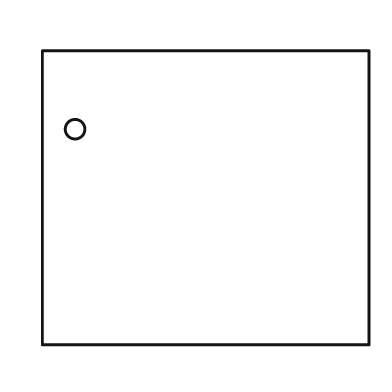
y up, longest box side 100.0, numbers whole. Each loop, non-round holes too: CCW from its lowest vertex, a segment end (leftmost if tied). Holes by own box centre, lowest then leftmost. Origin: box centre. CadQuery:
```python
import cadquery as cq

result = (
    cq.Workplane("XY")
    .moveTo(-50.0, -45.0)
    .lineTo(50.0, -45.0)
    .lineTo(50.0, 45.0)
    .lineTo(-50.0, 45.0)
    .close()
    .moveTo(-40.0, 21.0)
    .circle(3.0)
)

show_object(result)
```